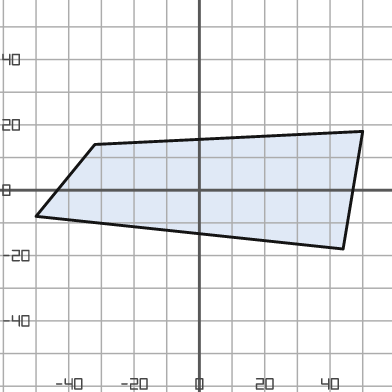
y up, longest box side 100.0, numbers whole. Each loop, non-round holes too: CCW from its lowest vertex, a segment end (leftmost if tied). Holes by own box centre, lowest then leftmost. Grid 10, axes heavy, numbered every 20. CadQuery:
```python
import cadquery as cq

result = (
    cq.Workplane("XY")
    .moveTo(44.0, -18.0)
    .lineTo(50.0, 18.0)
    .lineTo(-32.0, 14.0)
    .lineTo(-50.0, -8.0)
    .close()
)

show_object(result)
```